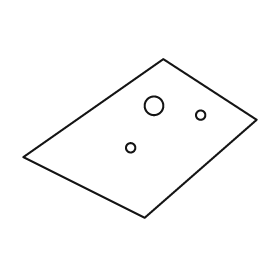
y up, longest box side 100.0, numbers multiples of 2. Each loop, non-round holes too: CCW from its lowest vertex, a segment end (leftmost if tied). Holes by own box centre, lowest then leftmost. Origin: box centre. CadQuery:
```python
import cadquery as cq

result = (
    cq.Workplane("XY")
    .moveTo(2.0, -34.0)
    .lineTo(50.0, 8.0)
    .lineTo(10.0, 34.0)
    .lineTo(-50.0, -8.0)
    .close()
    .moveTo(-4.0, -4.0)
    .circle(2.0)
    .moveTo(26.0, 10.0)
    .circle(2.0)
    .moveTo(6.0, 14.0)
    .circle(4.0)
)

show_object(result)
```